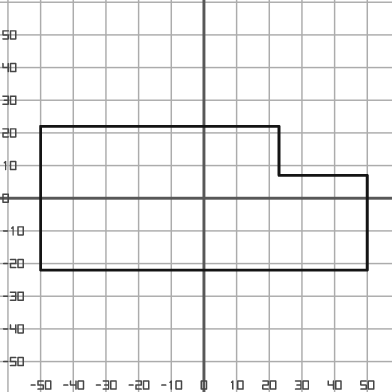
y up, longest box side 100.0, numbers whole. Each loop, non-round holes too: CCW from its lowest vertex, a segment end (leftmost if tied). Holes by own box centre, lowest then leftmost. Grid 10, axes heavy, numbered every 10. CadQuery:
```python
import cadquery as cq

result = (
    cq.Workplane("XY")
    .moveTo(-50.0, -22.0)
    .lineTo(50.0, -22.0)
    .lineTo(50.0, 7.0)
    .lineTo(23.0, 7.0)
    .lineTo(23.0, 22.0)
    .lineTo(-50.0, 22.0)
    .close()
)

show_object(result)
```